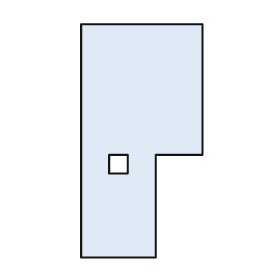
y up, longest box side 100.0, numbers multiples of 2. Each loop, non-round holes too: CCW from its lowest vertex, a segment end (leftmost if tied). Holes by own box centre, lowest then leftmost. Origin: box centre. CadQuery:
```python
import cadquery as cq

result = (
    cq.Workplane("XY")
    .moveTo(-26.0, -50.0)
    .lineTo(6.0, -50.0)
    .lineTo(6.0, -6.0)
    .lineTo(26.0, -6.0)
    .lineTo(26.0, 50.0)
    .lineTo(-26.0, 50.0)
    .close()
    .moveTo(-14.0, -14.0)
    .lineTo(-6.0, -14.0)
    .lineTo(-6.0, -6.0)
    .lineTo(-14.0, -6.0)
    .close()
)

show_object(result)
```